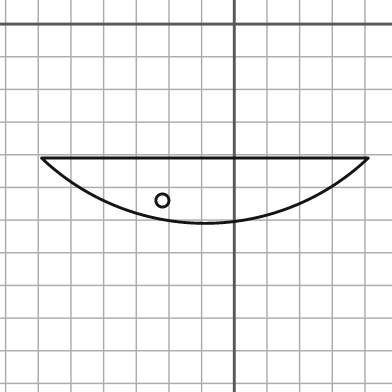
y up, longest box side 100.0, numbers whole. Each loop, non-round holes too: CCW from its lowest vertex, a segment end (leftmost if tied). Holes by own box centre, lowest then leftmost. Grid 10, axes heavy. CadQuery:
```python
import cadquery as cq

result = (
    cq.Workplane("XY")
    .moveTo(-59.0, -41.0)
    .threePointArc((-9.0, -61.0), (41.0, -41.0))
    .close()
    .moveTo(-22.0, -54.0)
    .circle(2.0)
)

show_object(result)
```